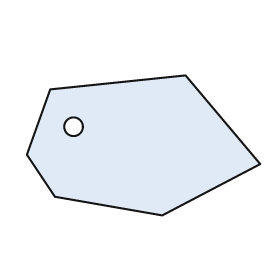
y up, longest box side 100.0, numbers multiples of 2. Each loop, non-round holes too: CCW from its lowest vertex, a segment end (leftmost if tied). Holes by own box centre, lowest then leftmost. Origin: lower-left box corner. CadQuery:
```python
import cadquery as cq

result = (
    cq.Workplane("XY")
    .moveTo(58.0, 0.0)
    .lineTo(100.0, 22.0)
    .lineTo(68.0, 60.0)
    .lineTo(10.0, 54.0)
    .lineTo(0.0, 26.0)
    .lineTo(12.0, 8.0)
    .close()
    .moveTo(20.0, 38.0)
    .circle(4.0)
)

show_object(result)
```